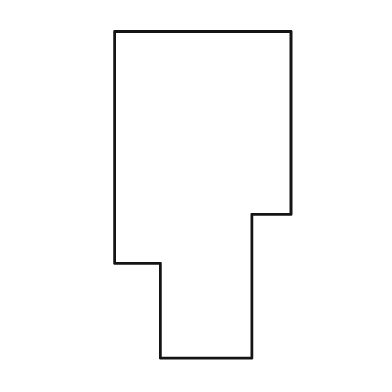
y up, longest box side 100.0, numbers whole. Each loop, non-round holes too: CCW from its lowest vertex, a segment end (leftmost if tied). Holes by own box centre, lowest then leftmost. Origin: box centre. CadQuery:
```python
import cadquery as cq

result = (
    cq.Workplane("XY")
    .moveTo(-13.0, -50.0)
    .lineTo(15.0, -50.0)
    .lineTo(15.0, -6.0)
    .lineTo(27.0, -6.0)
    .lineTo(27.0, 50.0)
    .lineTo(-27.0, 50.0)
    .lineTo(-27.0, -21.0)
    .lineTo(-13.0, -21.0)
    .close()
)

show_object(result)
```